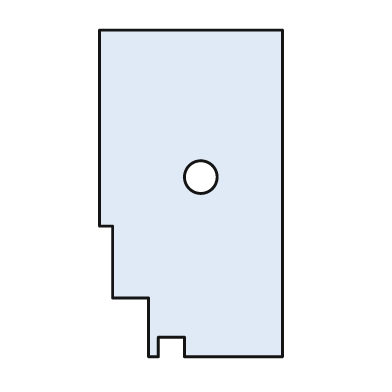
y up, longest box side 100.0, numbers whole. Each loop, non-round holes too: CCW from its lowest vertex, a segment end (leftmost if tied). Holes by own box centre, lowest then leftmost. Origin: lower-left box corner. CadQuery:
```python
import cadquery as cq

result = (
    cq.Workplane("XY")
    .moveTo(15.0, 0.0)
    .lineTo(18.0, 0.0)
    .lineTo(18.0, 6.0)
    .lineTo(26.0, 6.0)
    .lineTo(26.0, 0.0)
    .lineTo(56.0, 0.0)
    .lineTo(56.0, 100.0)
    .lineTo(0.0, 100.0)
    .lineTo(0.0, 40.0)
    .lineTo(4.0, 40.0)
    .lineTo(4.0, 18.0)
    .lineTo(15.0, 18.0)
    .close()
    .moveTo(31.0, 55.0)
    .circle(5.0)
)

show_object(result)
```